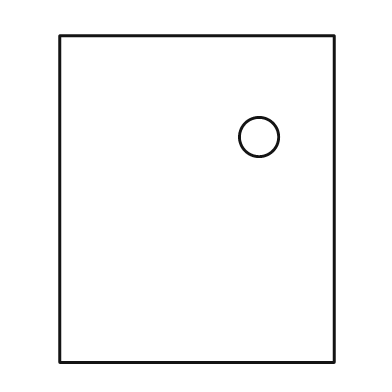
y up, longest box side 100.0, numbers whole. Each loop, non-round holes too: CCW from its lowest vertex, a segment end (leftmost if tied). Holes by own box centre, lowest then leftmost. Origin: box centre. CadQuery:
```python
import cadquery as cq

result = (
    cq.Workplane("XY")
    .moveTo(-42.0, -50.0)
    .lineTo(42.0, -50.0)
    .lineTo(42.0, 50.0)
    .lineTo(-42.0, 50.0)
    .close()
    .moveTo(19.0, 19.0)
    .circle(6.0)
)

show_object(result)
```